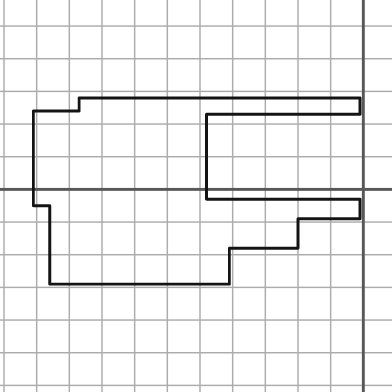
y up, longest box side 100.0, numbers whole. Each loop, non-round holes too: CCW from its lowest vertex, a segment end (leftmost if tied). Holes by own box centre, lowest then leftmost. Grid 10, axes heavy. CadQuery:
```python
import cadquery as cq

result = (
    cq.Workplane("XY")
    .moveTo(-96.0, -29.0)
    .lineTo(-41.0, -29.0)
    .lineTo(-41.0, -18.0)
    .lineTo(-20.0, -18.0)
    .lineTo(-20.0, -9.0)
    .lineTo(-1.0, -9.0)
    .lineTo(-1.0, -3.0)
    .lineTo(-48.0, -3.0)
    .lineTo(-48.0, 23.0)
    .lineTo(-1.0, 23.0)
    .lineTo(-1.0, 28.0)
    .lineTo(-87.0, 28.0)
    .lineTo(-87.0, 24.0)
    .lineTo(-101.0, 24.0)
    .lineTo(-101.0, -5.0)
    .lineTo(-96.0, -5.0)
    .close()
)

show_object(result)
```